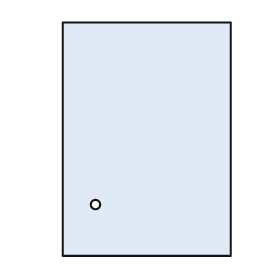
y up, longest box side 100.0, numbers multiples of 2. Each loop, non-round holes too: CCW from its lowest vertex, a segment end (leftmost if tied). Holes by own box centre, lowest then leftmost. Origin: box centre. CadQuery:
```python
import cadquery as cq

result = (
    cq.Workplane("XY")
    .moveTo(-36.0, -50.0)
    .lineTo(36.0, -50.0)
    .lineTo(36.0, 50.0)
    .lineTo(-36.0, 50.0)
    .close()
    .moveTo(-22.0, -28.0)
    .circle(2.0)
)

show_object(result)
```